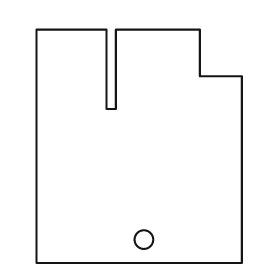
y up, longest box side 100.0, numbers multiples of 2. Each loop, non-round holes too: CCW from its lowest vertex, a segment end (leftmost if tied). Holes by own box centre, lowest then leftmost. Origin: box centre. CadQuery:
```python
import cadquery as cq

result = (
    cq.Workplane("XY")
    .moveTo(-44.0, -50.0)
    .lineTo(44.0, -50.0)
    .lineTo(44.0, 30.0)
    .lineTo(26.0, 30.0)
    .lineTo(26.0, 50.0)
    .lineTo(-10.0, 50.0)
    .lineTo(-10.0, 16.0)
    .lineTo(-14.0, 16.0)
    .lineTo(-14.0, 50.0)
    .lineTo(-44.0, 50.0)
    .close()
    .moveTo(2.0, -40.0)
    .circle(4.0)
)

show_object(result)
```